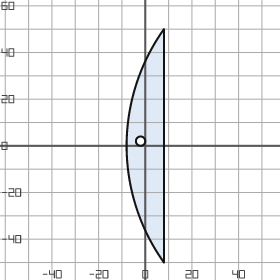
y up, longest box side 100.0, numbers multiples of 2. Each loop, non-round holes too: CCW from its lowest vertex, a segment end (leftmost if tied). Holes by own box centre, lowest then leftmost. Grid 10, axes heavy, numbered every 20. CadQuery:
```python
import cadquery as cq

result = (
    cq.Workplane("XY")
    .moveTo(8.0, -50.0)
    .lineTo(8.0, 50.0)
    .threePointArc((-8.0, 0.0), (8.0, -50.0))
    .close()
    .moveTo(-2.0, 2.0)
    .circle(2.0)
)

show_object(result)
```